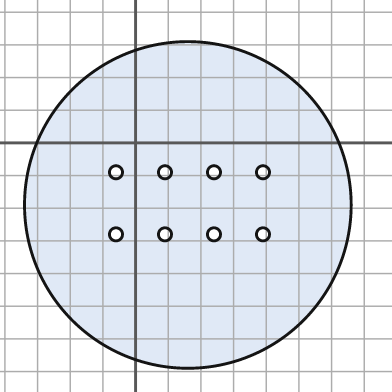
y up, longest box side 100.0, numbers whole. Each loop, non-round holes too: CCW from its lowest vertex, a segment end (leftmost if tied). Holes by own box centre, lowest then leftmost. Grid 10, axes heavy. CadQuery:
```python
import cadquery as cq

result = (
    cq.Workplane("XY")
    .moveTo(16.0, -19.0)
    .circle(50.0)
    .moveTo(-6.0, -28.0)
    .circle(2.0)
    .moveTo(9.0, -28.0)
    .circle(2.0)
    .moveTo(24.0, -28.0)
    .circle(2.0)
    .moveTo(39.0, -28.0)
    .circle(2.0)
    .moveTo(-6.0, -9.0)
    .circle(2.0)
    .moveTo(9.0, -9.0)
    .circle(2.0)
    .moveTo(24.0, -9.0)
    .circle(2.0)
    .moveTo(39.0, -9.0)
    .circle(2.0)
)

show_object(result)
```